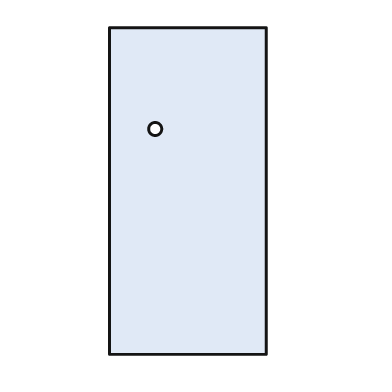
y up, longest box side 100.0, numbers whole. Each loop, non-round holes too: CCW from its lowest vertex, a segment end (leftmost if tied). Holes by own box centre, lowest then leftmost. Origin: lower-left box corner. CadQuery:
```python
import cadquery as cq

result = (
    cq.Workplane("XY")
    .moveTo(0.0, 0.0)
    .lineTo(48.0, 0.0)
    .lineTo(48.0, 100.0)
    .lineTo(0.0, 100.0)
    .close()
    .moveTo(14.0, 69.0)
    .circle(2.0)
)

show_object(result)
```